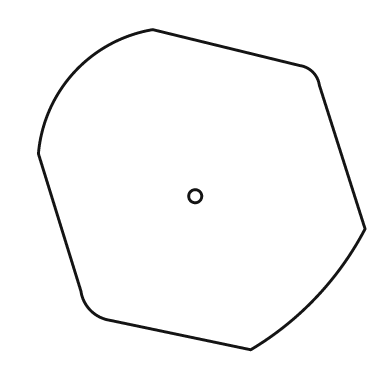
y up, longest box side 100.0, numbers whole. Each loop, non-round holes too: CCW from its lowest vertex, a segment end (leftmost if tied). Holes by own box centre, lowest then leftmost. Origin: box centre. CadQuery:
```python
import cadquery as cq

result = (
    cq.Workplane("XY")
    .moveTo(15.0, -49.0)
    .threePointArc((35.0, -33.0), (50.0, -12.0))
    .lineTo(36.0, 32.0)
    .threePointArc((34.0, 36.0), (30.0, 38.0))
    .lineTo(-15.0, 49.0)
    .threePointArc((-39.0, 36.0), (-50.0, 11.0))
    .lineTo(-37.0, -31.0)
    .threePointArc((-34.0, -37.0), (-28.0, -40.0))
    .close()
    .moveTo(-2.0, -2.0)
    .circle(2.0)
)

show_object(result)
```